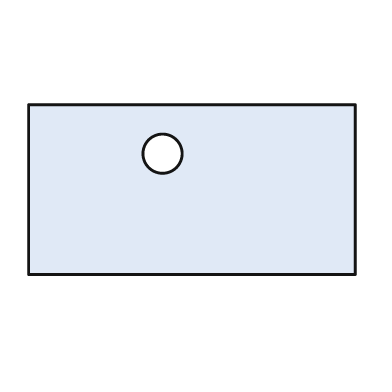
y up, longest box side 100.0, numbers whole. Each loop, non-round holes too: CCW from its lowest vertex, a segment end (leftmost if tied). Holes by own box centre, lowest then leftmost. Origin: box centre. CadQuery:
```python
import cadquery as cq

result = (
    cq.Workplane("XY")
    .moveTo(-50.0, -26.0)
    .lineTo(50.0, -26.0)
    .lineTo(50.0, 26.0)
    .lineTo(-50.0, 26.0)
    .close()
    .moveTo(-9.0, 11.0)
    .circle(6.0)
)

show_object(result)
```